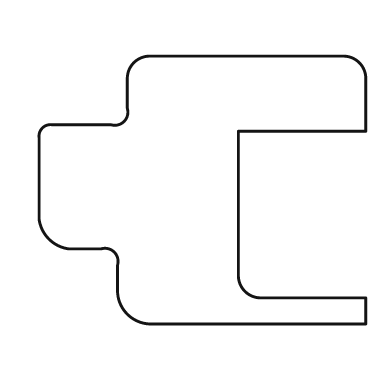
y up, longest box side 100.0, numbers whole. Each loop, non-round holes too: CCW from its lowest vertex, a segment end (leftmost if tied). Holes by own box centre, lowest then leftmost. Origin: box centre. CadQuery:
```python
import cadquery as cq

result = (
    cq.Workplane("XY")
    .moveTo(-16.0, -41.0)
    .lineTo(50.0, -41.0)
    .lineTo(50.0, -33.0)
    .lineTo(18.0, -33.0)
    .threePointArc((13.0, -31.0), (11.0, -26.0))
    .lineTo(11.0, 18.0)
    .lineTo(50.0, 18.0)
    .lineTo(50.0, 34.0)
    .threePointArc((48.0, 39.0), (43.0, 41.0))
    .lineTo(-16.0, 41.0)
    .threePointArc((-21.0, 39.0), (-23.0, 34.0))
    .lineTo(-23.0, 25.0)
    .threePointArc((-24.0, 21.0), (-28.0, 20.0))
    .lineTo(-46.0, 20.0)
    .threePointArc((-49.0, 19.0), (-50.0, 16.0))
    .lineTo(-50.0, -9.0)
    .threePointArc((-47.0, -15.0), (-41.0, -18.0))
    .lineTo(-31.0, -18.0)
    .threePointArc((-27.0, -19.0), (-26.0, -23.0))
    .lineTo(-26.0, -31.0)
    .threePointArc((-23.0, -38.0), (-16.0, -41.0))
    .close()
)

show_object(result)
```